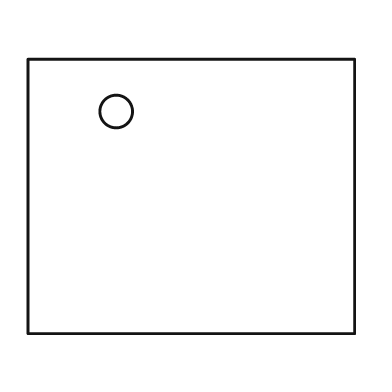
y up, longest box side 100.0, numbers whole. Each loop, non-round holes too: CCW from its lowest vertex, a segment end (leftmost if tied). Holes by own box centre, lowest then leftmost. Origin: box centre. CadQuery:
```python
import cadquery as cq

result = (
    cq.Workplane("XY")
    .moveTo(-50.0, -42.0)
    .lineTo(50.0, -42.0)
    .lineTo(50.0, 42.0)
    .lineTo(-50.0, 42.0)
    .close()
    .moveTo(-23.0, 26.0)
    .circle(5.0)
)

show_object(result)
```